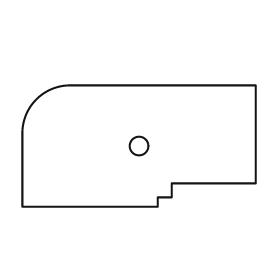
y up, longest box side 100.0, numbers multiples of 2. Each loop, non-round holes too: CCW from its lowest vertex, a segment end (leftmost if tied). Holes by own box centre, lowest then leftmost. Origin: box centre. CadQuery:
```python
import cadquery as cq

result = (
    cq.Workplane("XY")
    .moveTo(-50.0, -26.0)
    .lineTo(8.0, -26.0)
    .lineTo(8.0, -22.0)
    .lineTo(14.0, -22.0)
    .lineTo(14.0, -16.0)
    .lineTo(50.0, -16.0)
    .lineTo(50.0, 26.0)
    .lineTo(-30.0, 26.0)
    .threePointArc((-44.0, 20.0), (-50.0, 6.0))
    .close()
    .moveTo(0.0, 0.0)
    .circle(4.0)
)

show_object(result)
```